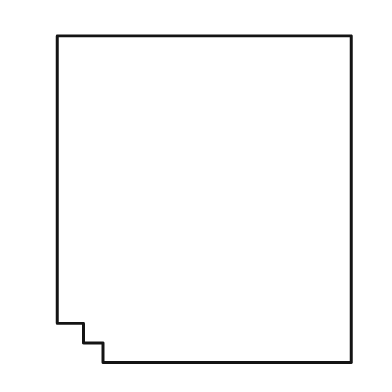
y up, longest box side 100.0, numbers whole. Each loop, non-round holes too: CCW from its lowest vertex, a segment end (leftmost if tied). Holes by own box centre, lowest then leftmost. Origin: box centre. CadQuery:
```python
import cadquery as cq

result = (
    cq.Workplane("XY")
    .moveTo(-31.0, -50.0)
    .lineTo(45.0, -50.0)
    .lineTo(45.0, 50.0)
    .lineTo(-45.0, 50.0)
    .lineTo(-45.0, -38.0)
    .lineTo(-37.0, -38.0)
    .lineTo(-37.0, -44.0)
    .lineTo(-31.0, -44.0)
    .close()
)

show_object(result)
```